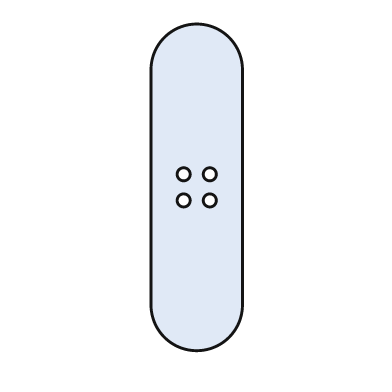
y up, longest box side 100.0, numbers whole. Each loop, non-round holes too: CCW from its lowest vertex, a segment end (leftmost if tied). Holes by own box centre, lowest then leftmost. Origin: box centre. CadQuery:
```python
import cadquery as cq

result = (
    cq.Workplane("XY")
    .moveTo(-14.0, -36.0)
    .threePointArc((0.0, -50.0), (14.0, -36.0))
    .lineTo(14.0, 36.0)
    .threePointArc((0.0, 50.0), (-14.0, 36.0))
    .close()
    .moveTo(-4.0, -4.0)
    .circle(2.0)
    .moveTo(4.0, -4.0)
    .circle(2.0)
    .moveTo(-4.0, 4.0)
    .circle(2.0)
    .moveTo(4.0, 4.0)
    .circle(2.0)
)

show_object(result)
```